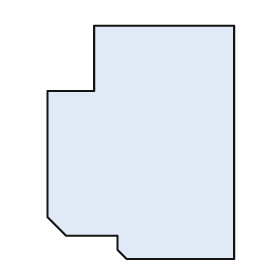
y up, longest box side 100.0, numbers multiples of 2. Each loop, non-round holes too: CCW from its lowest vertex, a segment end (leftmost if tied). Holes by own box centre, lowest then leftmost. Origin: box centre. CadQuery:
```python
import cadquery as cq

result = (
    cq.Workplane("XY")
    .moveTo(-6.0, -50.0)
    .lineTo(40.0, -50.0)
    .lineTo(40.0, 50.0)
    .lineTo(-20.0, 50.0)
    .lineTo(-20.0, 22.0)
    .lineTo(-40.0, 22.0)
    .lineTo(-40.0, -32.0)
    .lineTo(-32.0, -40.0)
    .lineTo(-10.0, -40.0)
    .lineTo(-10.0, -46.0)
    .close()
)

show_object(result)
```